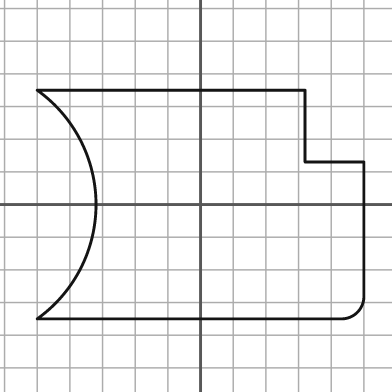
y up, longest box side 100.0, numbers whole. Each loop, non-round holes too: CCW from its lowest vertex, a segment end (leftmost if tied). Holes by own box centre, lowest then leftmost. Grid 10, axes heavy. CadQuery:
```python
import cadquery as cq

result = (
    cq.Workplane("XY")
    .moveTo(-50.0, -35.0)
    .lineTo(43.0, -35.0)
    .threePointArc((48.0, -33.0), (50.0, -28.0))
    .lineTo(50.0, 13.0)
    .lineTo(32.0, 13.0)
    .lineTo(32.0, 35.0)
    .lineTo(-50.0, 35.0)
    .threePointArc((-32.0, 0.0), (-50.0, -35.0))
    .close()
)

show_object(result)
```